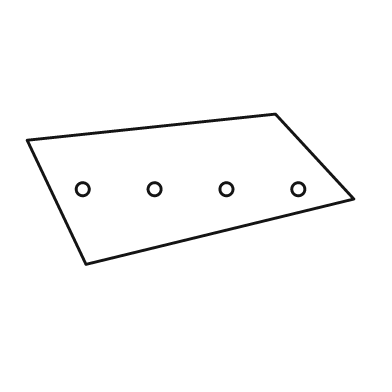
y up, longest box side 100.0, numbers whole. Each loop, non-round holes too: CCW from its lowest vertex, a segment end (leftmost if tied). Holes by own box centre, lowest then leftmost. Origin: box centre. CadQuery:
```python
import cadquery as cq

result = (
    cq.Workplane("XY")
    .moveTo(-32.0, -23.0)
    .lineTo(50.0, -3.0)
    .lineTo(26.0, 23.0)
    .lineTo(-50.0, 15.0)
    .close()
    .moveTo(-33.0, 0.0)
    .circle(2.0)
    .moveTo(-11.0, 0.0)
    .circle(2.0)
    .moveTo(11.0, 0.0)
    .circle(2.0)
    .moveTo(33.0, 0.0)
    .circle(2.0)
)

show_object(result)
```